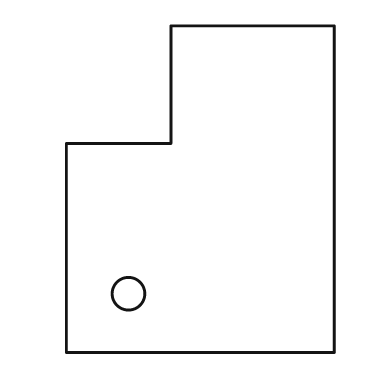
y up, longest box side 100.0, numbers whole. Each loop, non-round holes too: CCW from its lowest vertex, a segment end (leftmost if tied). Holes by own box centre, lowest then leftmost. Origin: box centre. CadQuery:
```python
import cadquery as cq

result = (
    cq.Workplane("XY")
    .moveTo(-41.0, -50.0)
    .lineTo(41.0, -50.0)
    .lineTo(41.0, 50.0)
    .lineTo(-9.0, 50.0)
    .lineTo(-9.0, 14.0)
    .lineTo(-41.0, 14.0)
    .close()
    .moveTo(-22.0, -32.0)
    .circle(5.0)
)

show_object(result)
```